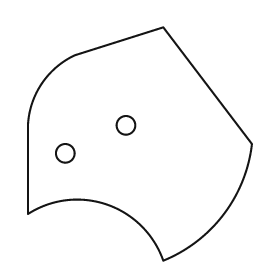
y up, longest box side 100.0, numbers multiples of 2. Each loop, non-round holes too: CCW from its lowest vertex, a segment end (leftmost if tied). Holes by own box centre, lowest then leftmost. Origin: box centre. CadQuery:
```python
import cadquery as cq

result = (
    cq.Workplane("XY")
    .moveTo(10.0, -50.0)
    .threePointArc((36.0, -30.0), (48.0, 0.0))
    .lineTo(10.0, 50.0)
    .lineTo(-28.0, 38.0)
    .threePointArc((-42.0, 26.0), (-48.0, 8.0))
    .lineTo(-48.0, -30.0)
    .threePointArc((-14.0, -26.0), (10.0, -50.0))
    .close()
    .moveTo(-32.0, -4.0)
    .circle(4.0)
    .moveTo(-6.0, 8.0)
    .circle(4.0)
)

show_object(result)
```